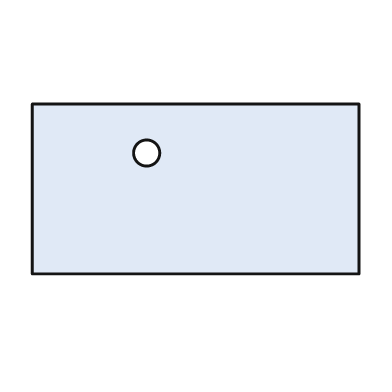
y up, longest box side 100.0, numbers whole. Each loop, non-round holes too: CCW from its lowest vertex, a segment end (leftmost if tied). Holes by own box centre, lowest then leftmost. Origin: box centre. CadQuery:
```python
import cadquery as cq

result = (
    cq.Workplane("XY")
    .moveTo(-50.0, -26.0)
    .lineTo(50.0, -26.0)
    .lineTo(50.0, 26.0)
    .lineTo(-50.0, 26.0)
    .close()
    .moveTo(-15.0, 11.0)
    .circle(4.0)
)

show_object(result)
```